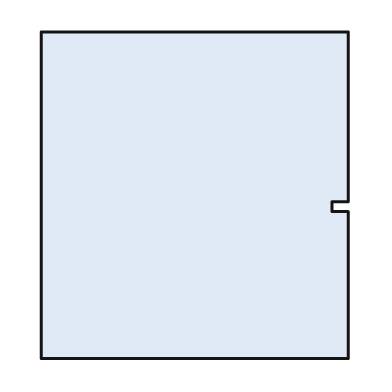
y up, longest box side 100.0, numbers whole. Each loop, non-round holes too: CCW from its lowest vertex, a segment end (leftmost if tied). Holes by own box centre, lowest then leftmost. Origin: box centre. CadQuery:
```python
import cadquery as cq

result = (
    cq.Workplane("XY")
    .moveTo(-47.0, -50.0)
    .lineTo(47.0, -50.0)
    .lineTo(47.0, -5.0)
    .lineTo(42.0, -5.0)
    .lineTo(42.0, -2.0)
    .lineTo(47.0, -2.0)
    .lineTo(47.0, 50.0)
    .lineTo(-47.0, 50.0)
    .close()
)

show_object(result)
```